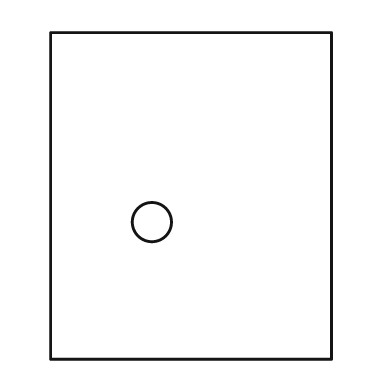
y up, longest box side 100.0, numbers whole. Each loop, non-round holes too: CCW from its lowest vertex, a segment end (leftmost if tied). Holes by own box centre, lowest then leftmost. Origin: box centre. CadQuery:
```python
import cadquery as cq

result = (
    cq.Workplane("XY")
    .moveTo(-43.0, -50.0)
    .lineTo(43.0, -50.0)
    .lineTo(43.0, 50.0)
    .lineTo(-43.0, 50.0)
    .close()
    .moveTo(-12.0, -8.0)
    .circle(6.0)
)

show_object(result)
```